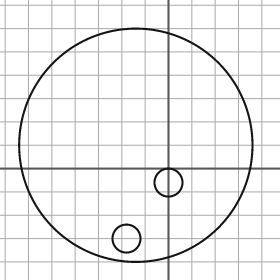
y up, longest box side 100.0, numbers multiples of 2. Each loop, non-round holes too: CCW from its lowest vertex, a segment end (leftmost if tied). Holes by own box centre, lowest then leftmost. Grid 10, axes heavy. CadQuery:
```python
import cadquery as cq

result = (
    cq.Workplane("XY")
    .moveTo(-14.0, 10.0)
    .circle(50.0)
    .moveTo(-18.0, -30.0)
    .circle(6.0)
    .moveTo(0.0, -6.0)
    .circle(6.0)
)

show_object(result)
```